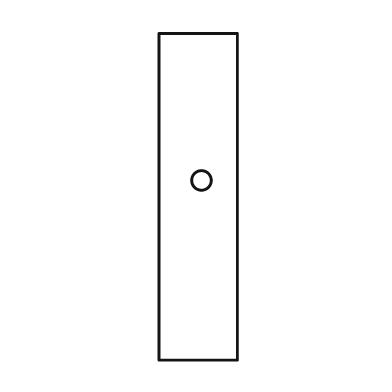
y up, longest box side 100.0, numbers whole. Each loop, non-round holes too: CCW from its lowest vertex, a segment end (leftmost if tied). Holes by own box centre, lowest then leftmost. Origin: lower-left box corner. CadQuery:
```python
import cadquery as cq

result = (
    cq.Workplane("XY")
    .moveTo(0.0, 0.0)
    .lineTo(24.0, 0.0)
    .lineTo(24.0, 100.0)
    .lineTo(0.0, 100.0)
    .close()
    .moveTo(13.0, 55.0)
    .circle(3.0)
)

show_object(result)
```